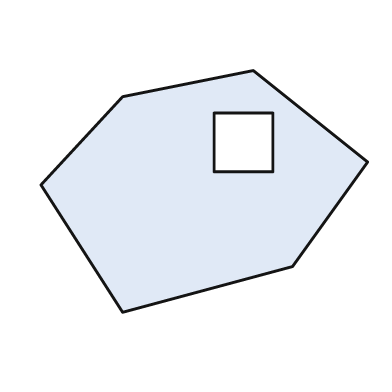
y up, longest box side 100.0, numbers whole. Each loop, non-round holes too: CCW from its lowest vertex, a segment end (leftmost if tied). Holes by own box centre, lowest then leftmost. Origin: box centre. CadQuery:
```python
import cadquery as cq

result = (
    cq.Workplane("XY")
    .moveTo(-25.0, -37.0)
    .lineTo(27.0, -23.0)
    .lineTo(50.0, 9.0)
    .lineTo(15.0, 37.0)
    .lineTo(-25.0, 29.0)
    .lineTo(-50.0, 2.0)
    .close()
    .moveTo(3.0, 6.0)
    .lineTo(21.0, 6.0)
    .lineTo(21.0, 24.0)
    .lineTo(3.0, 24.0)
    .close()
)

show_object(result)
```